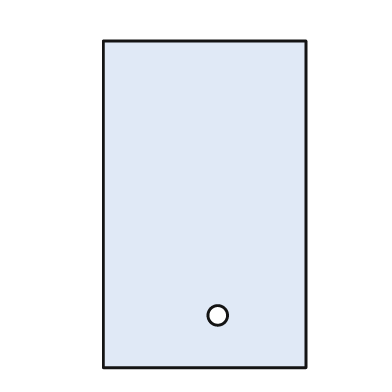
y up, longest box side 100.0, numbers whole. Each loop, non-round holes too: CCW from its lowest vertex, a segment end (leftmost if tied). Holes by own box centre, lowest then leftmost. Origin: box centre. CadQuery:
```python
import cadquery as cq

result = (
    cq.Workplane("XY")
    .moveTo(-31.0, -50.0)
    .lineTo(31.0, -50.0)
    .lineTo(31.0, 50.0)
    .lineTo(-31.0, 50.0)
    .close()
    .moveTo(4.0, -34.0)
    .circle(3.0)
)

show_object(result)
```